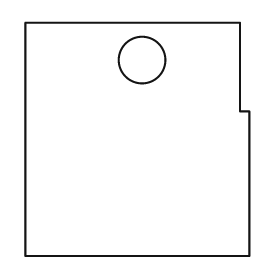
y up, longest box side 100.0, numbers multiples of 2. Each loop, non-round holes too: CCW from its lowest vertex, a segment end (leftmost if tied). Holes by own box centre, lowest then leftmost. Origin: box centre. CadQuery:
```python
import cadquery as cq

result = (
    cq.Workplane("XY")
    .moveTo(-48.0, -50.0)
    .lineTo(48.0, -50.0)
    .lineTo(48.0, 12.0)
    .lineTo(44.0, 12.0)
    .lineTo(44.0, 50.0)
    .lineTo(-48.0, 50.0)
    .close()
    .moveTo(2.0, 34.0)
    .circle(10.0)
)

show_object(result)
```